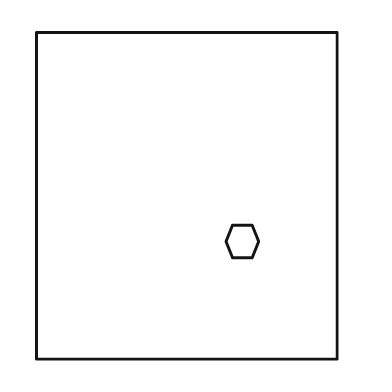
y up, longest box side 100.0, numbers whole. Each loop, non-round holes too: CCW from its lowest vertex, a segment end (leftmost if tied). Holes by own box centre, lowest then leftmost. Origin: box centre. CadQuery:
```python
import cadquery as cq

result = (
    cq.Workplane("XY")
    .moveTo(-46.0, -50.0)
    .lineTo(46.0, -50.0)
    .lineTo(46.0, 50.0)
    .lineTo(-46.0, 50.0)
    .close()
    .moveTo(14.0, -19.0)
    .lineTo(20.0, -19.0)
    .lineTo(22.0, -14.0)
    .lineTo(20.0, -9.0)
    .lineTo(14.0, -9.0)
    .lineTo(12.0, -14.0)
    .close()
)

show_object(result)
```